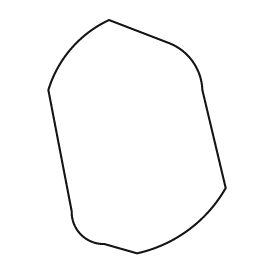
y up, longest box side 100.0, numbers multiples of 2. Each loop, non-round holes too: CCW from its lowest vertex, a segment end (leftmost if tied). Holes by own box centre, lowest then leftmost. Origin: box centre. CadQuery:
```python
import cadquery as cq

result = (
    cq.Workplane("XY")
    .moveTo(0.0, -50.0)
    .threePointArc((22.0, -40.0), (38.0, -22.0))
    .lineTo(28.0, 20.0)
    .threePointArc((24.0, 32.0), (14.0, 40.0))
    .lineTo(-12.0, 50.0)
    .threePointArc((-28.0, 38.0), (-38.0, 20.0))
    .lineTo(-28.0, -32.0)
    .threePointArc((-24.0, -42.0), (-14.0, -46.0))
    .close()
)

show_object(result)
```